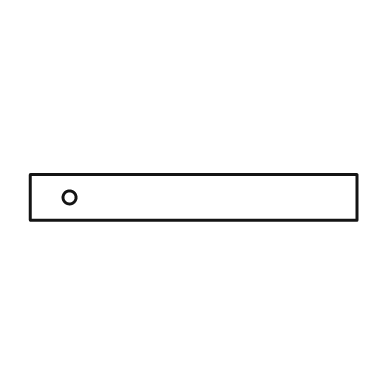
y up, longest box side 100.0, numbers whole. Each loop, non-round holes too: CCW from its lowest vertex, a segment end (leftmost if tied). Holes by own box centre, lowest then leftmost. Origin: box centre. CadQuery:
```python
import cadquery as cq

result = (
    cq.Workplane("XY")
    .moveTo(-50.0, -7.0)
    .lineTo(50.0, -7.0)
    .lineTo(50.0, 7.0)
    .lineTo(-50.0, 7.0)
    .close()
    .moveTo(-38.0, 0.0)
    .circle(2.0)
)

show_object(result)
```